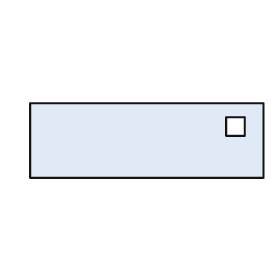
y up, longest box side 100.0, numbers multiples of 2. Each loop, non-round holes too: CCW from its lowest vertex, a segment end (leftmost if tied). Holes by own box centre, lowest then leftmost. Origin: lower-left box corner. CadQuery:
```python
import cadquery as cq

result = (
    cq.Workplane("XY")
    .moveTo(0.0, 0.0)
    .lineTo(100.0, 0.0)
    .lineTo(100.0, 32.0)
    .lineTo(0.0, 32.0)
    .close()
    .moveTo(84.0, 18.0)
    .lineTo(92.0, 18.0)
    .lineTo(92.0, 26.0)
    .lineTo(84.0, 26.0)
    .close()
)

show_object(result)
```